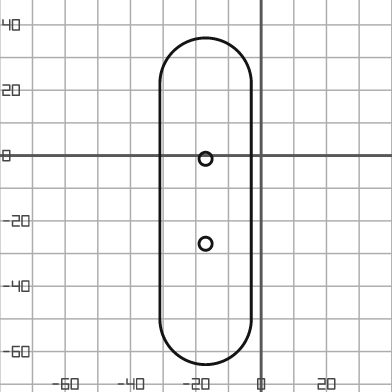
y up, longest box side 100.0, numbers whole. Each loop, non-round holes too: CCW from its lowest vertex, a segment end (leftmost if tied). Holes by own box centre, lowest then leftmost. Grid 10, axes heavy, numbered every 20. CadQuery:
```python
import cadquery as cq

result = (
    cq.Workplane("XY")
    .moveTo(-31.0, -50.0)
    .threePointArc((-17.0, -64.0), (-3.0, -50.0))
    .lineTo(-3.0, 22.0)
    .threePointArc((-17.0, 36.0), (-31.0, 22.0))
    .close()
    .moveTo(-17.0, -27.0)
    .circle(2.0)
    .moveTo(-17.0, -1.0)
    .circle(2.0)
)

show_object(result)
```